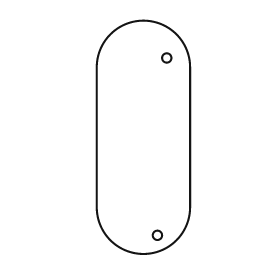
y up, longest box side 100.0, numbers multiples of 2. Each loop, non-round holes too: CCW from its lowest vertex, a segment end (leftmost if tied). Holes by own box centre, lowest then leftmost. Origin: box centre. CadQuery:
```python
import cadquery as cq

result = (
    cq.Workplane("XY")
    .moveTo(-20.0, -30.0)
    .threePointArc((0.0, -50.0), (20.0, -30.0))
    .lineTo(20.0, 30.0)
    .threePointArc((0.0, 50.0), (-20.0, 30.0))
    .close()
    .moveTo(6.0, -42.0)
    .circle(2.0)
    .moveTo(10.0, 34.0)
    .circle(2.0)
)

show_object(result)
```